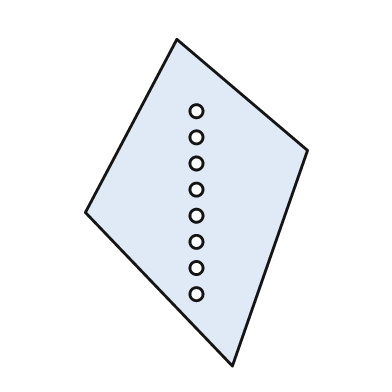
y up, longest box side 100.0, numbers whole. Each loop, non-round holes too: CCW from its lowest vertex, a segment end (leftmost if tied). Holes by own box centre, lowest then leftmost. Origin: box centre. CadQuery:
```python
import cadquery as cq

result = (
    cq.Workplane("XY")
    .moveTo(11.0, -50.0)
    .lineTo(34.0, 16.0)
    .lineTo(-6.0, 50.0)
    .lineTo(-34.0, -3.0)
    .close()
    .moveTo(0.0, -28.0)
    .circle(2.0)
    .moveTo(0.0, -20.0)
    .circle(2.0)
    .moveTo(0.0, -12.0)
    .circle(2.0)
    .moveTo(0.0, -4.0)
    .circle(2.0)
    .moveTo(0.0, 4.0)
    .circle(2.0)
    .moveTo(0.0, 12.0)
    .circle(2.0)
    .moveTo(0.0, 20.0)
    .circle(2.0)
    .moveTo(0.0, 28.0)
    .circle(2.0)
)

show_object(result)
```